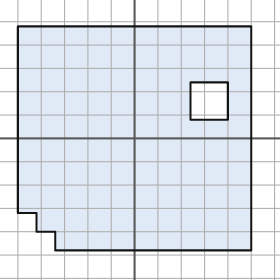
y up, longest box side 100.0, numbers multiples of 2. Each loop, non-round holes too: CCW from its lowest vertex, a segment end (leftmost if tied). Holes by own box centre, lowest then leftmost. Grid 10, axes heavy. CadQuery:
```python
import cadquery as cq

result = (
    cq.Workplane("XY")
    .moveTo(-34.0, -48.0)
    .lineTo(50.0, -48.0)
    .lineTo(50.0, 48.0)
    .lineTo(-50.0, 48.0)
    .lineTo(-50.0, -32.0)
    .lineTo(-42.0, -32.0)
    .lineTo(-42.0, -40.0)
    .lineTo(-34.0, -40.0)
    .close()
    .moveTo(24.0, 8.0)
    .lineTo(40.0, 8.0)
    .lineTo(40.0, 24.0)
    .lineTo(24.0, 24.0)
    .close()
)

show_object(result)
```